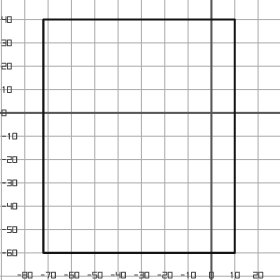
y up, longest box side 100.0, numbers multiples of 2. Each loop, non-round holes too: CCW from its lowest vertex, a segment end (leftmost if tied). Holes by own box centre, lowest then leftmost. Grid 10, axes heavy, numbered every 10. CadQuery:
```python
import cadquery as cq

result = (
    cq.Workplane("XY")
    .moveTo(-72.0, -60.0)
    .lineTo(10.0, -60.0)
    .lineTo(10.0, 40.0)
    .lineTo(-72.0, 40.0)
    .close()
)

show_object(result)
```